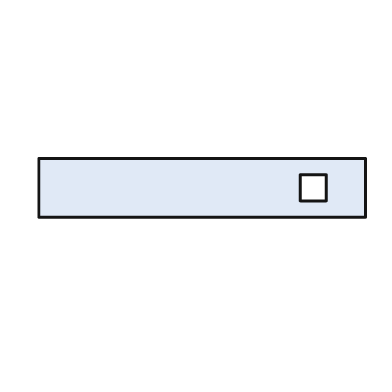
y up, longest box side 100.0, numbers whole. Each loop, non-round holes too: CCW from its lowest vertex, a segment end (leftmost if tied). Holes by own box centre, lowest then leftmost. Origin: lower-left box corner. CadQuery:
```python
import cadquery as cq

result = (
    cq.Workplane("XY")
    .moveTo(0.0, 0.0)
    .lineTo(100.0, 0.0)
    .lineTo(100.0, 18.0)
    .lineTo(0.0, 18.0)
    .close()
    .moveTo(80.0, 5.0)
    .lineTo(88.0, 5.0)
    .lineTo(88.0, 13.0)
    .lineTo(80.0, 13.0)
    .close()
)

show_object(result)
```